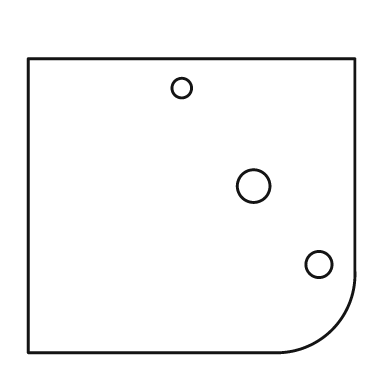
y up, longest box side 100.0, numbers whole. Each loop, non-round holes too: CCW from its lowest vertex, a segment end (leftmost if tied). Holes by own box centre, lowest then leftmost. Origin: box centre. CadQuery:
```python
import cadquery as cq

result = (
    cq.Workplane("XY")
    .moveTo(-50.0, -45.0)
    .lineTo(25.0, -45.0)
    .threePointArc((43.0, -38.0), (50.0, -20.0))
    .lineTo(50.0, 45.0)
    .lineTo(-50.0, 45.0)
    .close()
    .moveTo(39.0, -18.0)
    .circle(4.0)
    .moveTo(19.0, 6.0)
    .circle(5.0)
    .moveTo(-3.0, 36.0)
    .circle(3.0)
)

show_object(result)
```